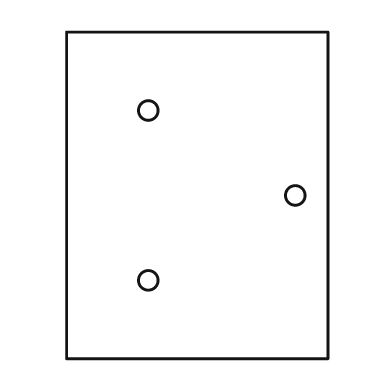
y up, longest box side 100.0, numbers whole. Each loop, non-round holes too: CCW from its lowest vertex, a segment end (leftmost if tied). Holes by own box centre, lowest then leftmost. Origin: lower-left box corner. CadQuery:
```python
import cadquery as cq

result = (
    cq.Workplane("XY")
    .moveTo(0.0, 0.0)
    .lineTo(80.0, 0.0)
    .lineTo(80.0, 100.0)
    .lineTo(0.0, 100.0)
    .close()
    .moveTo(25.0, 24.0)
    .circle(3.0)
    .moveTo(70.0, 50.0)
    .circle(3.0)
    .moveTo(25.0, 76.0)
    .circle(3.0)
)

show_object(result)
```